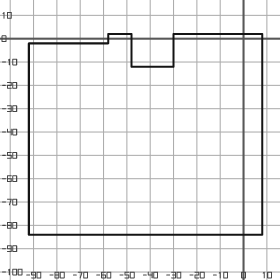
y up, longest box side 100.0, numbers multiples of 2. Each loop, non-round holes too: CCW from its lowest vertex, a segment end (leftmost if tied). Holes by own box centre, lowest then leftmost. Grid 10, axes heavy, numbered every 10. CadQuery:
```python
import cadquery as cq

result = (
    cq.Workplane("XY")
    .moveTo(-92.0, -84.0)
    .lineTo(8.0, -84.0)
    .lineTo(8.0, 2.0)
    .lineTo(-30.0, 2.0)
    .lineTo(-30.0, -12.0)
    .lineTo(-48.0, -12.0)
    .lineTo(-48.0, 2.0)
    .lineTo(-58.0, 2.0)
    .lineTo(-58.0, -2.0)
    .lineTo(-92.0, -2.0)
    .close()
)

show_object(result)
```